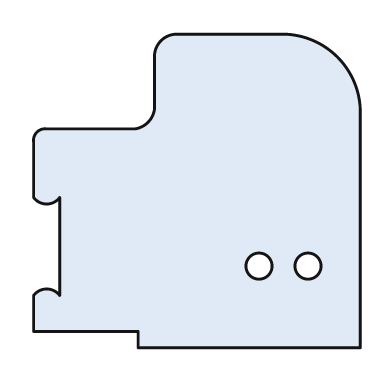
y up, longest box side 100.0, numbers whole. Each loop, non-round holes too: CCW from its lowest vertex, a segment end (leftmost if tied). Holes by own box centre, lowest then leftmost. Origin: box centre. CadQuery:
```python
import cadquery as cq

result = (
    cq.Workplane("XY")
    .moveTo(-18.0, -48.0)
    .lineTo(50.0, -48.0)
    .lineTo(50.0, 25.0)
    .threePointArc((43.0, 41.0), (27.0, 48.0))
    .lineTo(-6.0, 48.0)
    .threePointArc((-11.0, 46.0), (-13.0, 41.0))
    .lineTo(-13.0, 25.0)
    .threePointArc((-15.0, 21.0), (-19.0, 19.0))
    .lineTo(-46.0, 19.0)
    .threePointArc((-49.0, 18.0), (-50.0, 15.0))
    .lineTo(-50.0, -2.0)
    .threePointArc((-46.0, -4.0), (-42.0, -2.0))
    .lineTo(-42.0, -32.0)
    .threePointArc((-46.0, -30.0), (-50.0, -32.0))
    .lineTo(-50.0, -43.0)
    .lineTo(-18.0, -43.0)
    .close()
    .moveTo(19.0, -23.0)
    .circle(4.0)
    .moveTo(34.0, -23.0)
    .circle(4.0)
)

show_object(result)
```